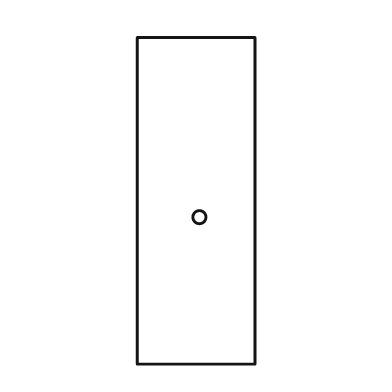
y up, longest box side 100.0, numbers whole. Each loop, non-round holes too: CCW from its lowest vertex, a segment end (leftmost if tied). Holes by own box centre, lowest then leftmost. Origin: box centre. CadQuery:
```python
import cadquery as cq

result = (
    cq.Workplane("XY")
    .moveTo(-18.0, -50.0)
    .lineTo(18.0, -50.0)
    .lineTo(18.0, 50.0)
    .lineTo(-18.0, 50.0)
    .close()
    .moveTo(1.0, -5.0)
    .circle(2.0)
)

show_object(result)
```